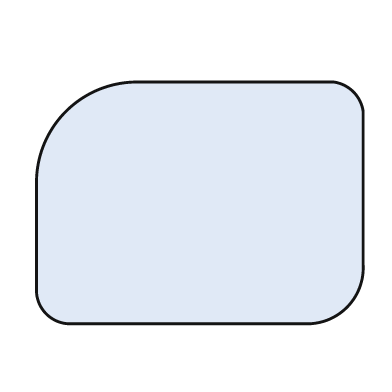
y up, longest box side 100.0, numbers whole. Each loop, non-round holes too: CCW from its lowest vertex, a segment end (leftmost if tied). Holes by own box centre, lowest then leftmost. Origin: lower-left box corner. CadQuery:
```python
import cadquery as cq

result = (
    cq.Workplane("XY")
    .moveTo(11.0, 0.0)
    .lineTo(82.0, 0.0)
    .threePointArc((95.0, 5.0), (100.0, 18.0))
    .lineTo(100.0, 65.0)
    .threePointArc((97.0, 71.0), (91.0, 74.0))
    .lineTo(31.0, 74.0)
    .threePointArc((9.0, 65.0), (0.0, 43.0))
    .lineTo(0.0, 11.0)
    .threePointArc((3.0, 3.0), (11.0, 0.0))
    .close()
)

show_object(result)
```